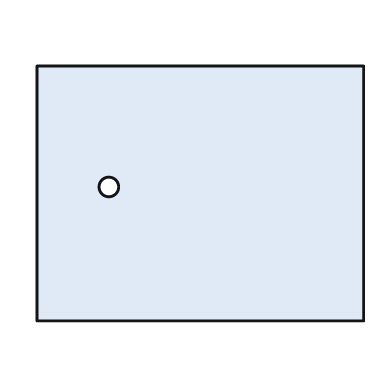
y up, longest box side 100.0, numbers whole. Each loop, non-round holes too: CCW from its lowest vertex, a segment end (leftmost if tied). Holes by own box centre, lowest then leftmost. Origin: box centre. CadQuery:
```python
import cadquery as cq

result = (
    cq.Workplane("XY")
    .moveTo(-50.0, -39.0)
    .lineTo(50.0, -39.0)
    .lineTo(50.0, 39.0)
    .lineTo(-50.0, 39.0)
    .close()
    .moveTo(-28.0, 2.0)
    .circle(3.0)
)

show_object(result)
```